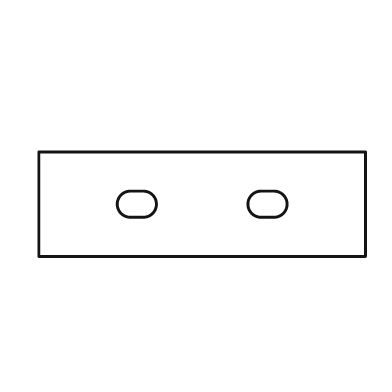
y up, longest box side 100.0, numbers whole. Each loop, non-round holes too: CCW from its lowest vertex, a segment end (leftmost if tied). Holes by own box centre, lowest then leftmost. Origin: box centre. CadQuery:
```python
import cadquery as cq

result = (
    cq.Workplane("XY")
    .moveTo(-50.0, -16.0)
    .lineTo(50.0, -16.0)
    .lineTo(50.0, 16.0)
    .lineTo(-50.0, 16.0)
    .close()
    .moveTo(-22.0, -4.0)
    .lineTo(-18.0, -4.0)
    .threePointArc((-14.0, 0.0), (-18.0, 4.0))
    .lineTo(-22.0, 4.0)
    .threePointArc((-26.0, 0.0), (-22.0, -4.0))
    .close()
    .moveTo(18.0, -4.0)
    .lineTo(22.0, -4.0)
    .threePointArc((26.0, 0.0), (22.0, 4.0))
    .lineTo(18.0, 4.0)
    .threePointArc((14.0, 0.0), (18.0, -4.0))
    .close()
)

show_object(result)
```